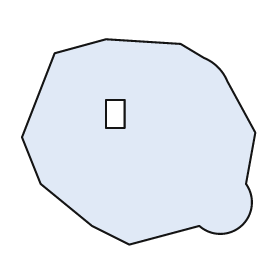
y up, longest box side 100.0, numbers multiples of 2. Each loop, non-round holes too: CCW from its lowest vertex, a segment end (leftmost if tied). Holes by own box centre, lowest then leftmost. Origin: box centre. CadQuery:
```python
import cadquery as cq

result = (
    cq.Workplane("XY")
    .moveTo(-4.0, -44.0)
    .lineTo(26.0, -36.0)
    .threePointArc((44.0, -36.0), (46.0, -18.0))
    .lineTo(50.0, 4.0)
    .lineTo(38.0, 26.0)
    .threePointArc((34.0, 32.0), (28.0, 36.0))
    .lineTo(18.0, 42.0)
    .lineTo(-14.0, 44.0)
    .lineTo(-36.0, 38.0)
    .lineTo(-50.0, 2.0)
    .lineTo(-42.0, -18.0)
    .lineTo(-20.0, -36.0)
    .close()
    .moveTo(-14.0, 6.0)
    .lineTo(-6.0, 6.0)
    .lineTo(-6.0, 18.0)
    .lineTo(-14.0, 18.0)
    .close()
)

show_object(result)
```